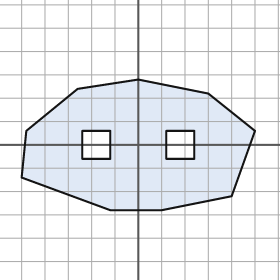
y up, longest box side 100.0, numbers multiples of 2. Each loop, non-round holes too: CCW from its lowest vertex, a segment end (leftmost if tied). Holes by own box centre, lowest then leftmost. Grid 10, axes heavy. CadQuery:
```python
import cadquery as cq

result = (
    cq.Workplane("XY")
    .moveTo(-12.0, -28.0)
    .lineTo(10.0, -28.0)
    .lineTo(40.0, -22.0)
    .lineTo(50.0, 6.0)
    .lineTo(30.0, 22.0)
    .lineTo(0.0, 28.0)
    .lineTo(-26.0, 24.0)
    .lineTo(-48.0, 6.0)
    .lineTo(-50.0, -14.0)
    .close()
    .moveTo(-24.0, -6.0)
    .lineTo(-12.0, -6.0)
    .lineTo(-12.0, 6.0)
    .lineTo(-24.0, 6.0)
    .close()
    .moveTo(12.0, -6.0)
    .lineTo(24.0, -6.0)
    .lineTo(24.0, 6.0)
    .lineTo(12.0, 6.0)
    .close()
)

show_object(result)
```